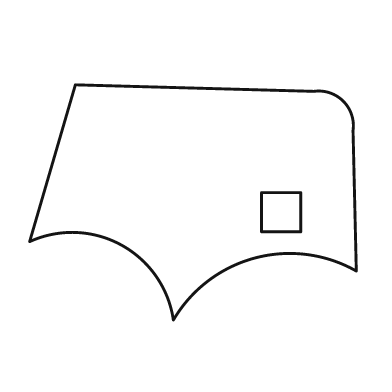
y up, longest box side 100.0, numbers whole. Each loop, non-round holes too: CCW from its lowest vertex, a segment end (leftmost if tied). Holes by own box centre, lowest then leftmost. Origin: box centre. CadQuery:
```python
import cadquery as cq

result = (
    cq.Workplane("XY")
    .moveTo(-6.0, -36.0)
    .threePointArc((19.0, -17.0), (50.0, -21.0))
    .lineTo(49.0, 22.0)
    .threePointArc((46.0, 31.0), (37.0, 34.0))
    .lineTo(-36.0, 36.0)
    .lineTo(-50.0, -12.0)
    .threePointArc((-22.0, -13.0), (-6.0, -36.0))
    .close()
    .moveTo(21.0, -9.0)
    .lineTo(33.0, -9.0)
    .lineTo(33.0, 3.0)
    .lineTo(21.0, 3.0)
    .close()
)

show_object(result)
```